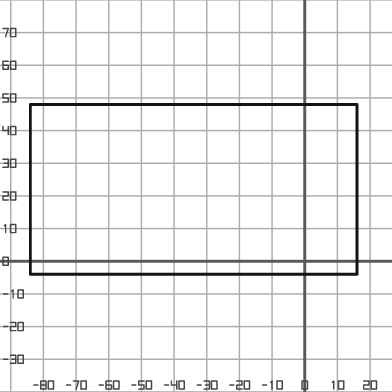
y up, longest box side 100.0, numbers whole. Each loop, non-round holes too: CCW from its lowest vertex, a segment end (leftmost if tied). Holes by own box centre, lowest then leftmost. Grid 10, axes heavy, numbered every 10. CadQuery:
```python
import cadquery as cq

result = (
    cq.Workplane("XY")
    .moveTo(-84.0, -4.0)
    .lineTo(16.0, -4.0)
    .lineTo(16.0, 48.0)
    .lineTo(-84.0, 48.0)
    .close()
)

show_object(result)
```